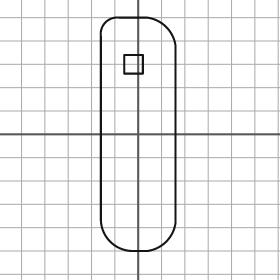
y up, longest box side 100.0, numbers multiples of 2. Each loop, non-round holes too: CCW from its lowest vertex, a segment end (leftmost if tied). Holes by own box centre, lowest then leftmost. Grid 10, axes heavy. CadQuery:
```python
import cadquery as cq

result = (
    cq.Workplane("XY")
    .moveTo(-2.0, -50.0)
    .lineTo(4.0, -50.0)
    .threePointArc((12.0, -46.0), (16.0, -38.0))
    .lineTo(16.0, 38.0)
    .threePointArc((12.0, 46.0), (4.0, 50.0))
    .lineTo(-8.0, 50.0)
    .threePointArc((-14.0, 48.0), (-16.0, 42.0))
    .lineTo(-16.0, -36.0)
    .threePointArc((-12.0, -46.0), (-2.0, -50.0))
    .close()
    .moveTo(-6.0, 26.0)
    .lineTo(2.0, 26.0)
    .lineTo(2.0, 34.0)
    .lineTo(-6.0, 34.0)
    .close()
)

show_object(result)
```